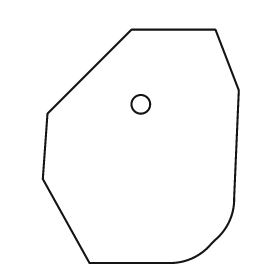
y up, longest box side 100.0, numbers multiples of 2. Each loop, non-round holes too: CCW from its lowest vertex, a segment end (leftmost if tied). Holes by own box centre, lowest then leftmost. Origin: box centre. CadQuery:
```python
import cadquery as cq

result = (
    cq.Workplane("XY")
    .moveTo(-22.0, -50.0)
    .lineTo(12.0, -50.0)
    .threePointArc((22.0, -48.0), (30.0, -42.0))
    .lineTo(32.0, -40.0)
    .threePointArc((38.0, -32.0), (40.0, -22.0))
    .lineTo(42.0, 24.0)
    .lineTo(32.0, 50.0)
    .lineTo(-4.0, 50.0)
    .lineTo(-40.0, 14.0)
    .lineTo(-42.0, -14.0)
    .close()
    .moveTo(0.0, 18.0)
    .circle(4.0)
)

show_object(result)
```